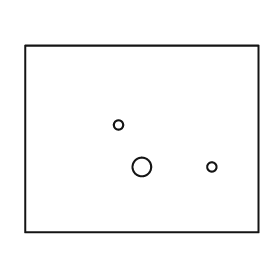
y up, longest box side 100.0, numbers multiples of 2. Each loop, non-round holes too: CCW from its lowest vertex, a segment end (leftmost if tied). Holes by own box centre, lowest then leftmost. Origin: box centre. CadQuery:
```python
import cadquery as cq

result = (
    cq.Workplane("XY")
    .moveTo(-50.0, -40.0)
    .lineTo(50.0, -40.0)
    .lineTo(50.0, 40.0)
    .lineTo(-50.0, 40.0)
    .close()
    .moveTo(0.0, -12.0)
    .circle(4.0)
    .moveTo(30.0, -12.0)
    .circle(2.0)
    .moveTo(-10.0, 6.0)
    .circle(2.0)
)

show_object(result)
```